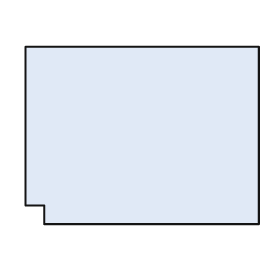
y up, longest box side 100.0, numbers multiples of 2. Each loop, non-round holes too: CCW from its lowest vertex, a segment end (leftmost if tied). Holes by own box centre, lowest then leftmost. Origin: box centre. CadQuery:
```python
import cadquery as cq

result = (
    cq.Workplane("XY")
    .moveTo(-42.0, -38.0)
    .lineTo(50.0, -38.0)
    .lineTo(50.0, 38.0)
    .lineTo(-50.0, 38.0)
    .lineTo(-50.0, -30.0)
    .lineTo(-42.0, -30.0)
    .close()
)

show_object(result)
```